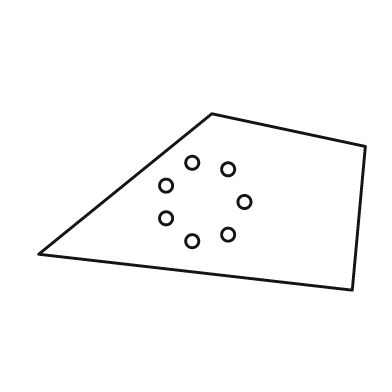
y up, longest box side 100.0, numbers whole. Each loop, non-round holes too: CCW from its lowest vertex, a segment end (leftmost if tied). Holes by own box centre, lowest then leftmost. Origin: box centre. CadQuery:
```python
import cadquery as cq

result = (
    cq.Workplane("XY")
    .moveTo(46.0, -27.0)
    .lineTo(50.0, 17.0)
    .lineTo(3.0, 27.0)
    .lineTo(-50.0, -16.0)
    .close()
    .moveTo(-3.0, -12.0)
    .circle(2.0)
    .moveTo(8.0, -10.0)
    .circle(2.0)
    .moveTo(-11.0, -5.0)
    .circle(2.0)
    .moveTo(13.0, 0.0)
    .circle(2.0)
    .moveTo(-11.0, 5.0)
    .circle(2.0)
    .moveTo(8.0, 10.0)
    .circle(2.0)
    .moveTo(-3.0, 12.0)
    .circle(2.0)
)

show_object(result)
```